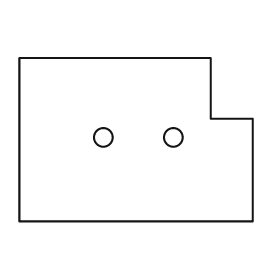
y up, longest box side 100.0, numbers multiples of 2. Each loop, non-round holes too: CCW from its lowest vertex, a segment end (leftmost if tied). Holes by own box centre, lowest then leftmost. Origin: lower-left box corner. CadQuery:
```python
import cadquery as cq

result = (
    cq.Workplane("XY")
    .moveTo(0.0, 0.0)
    .lineTo(100.0, 0.0)
    .lineTo(100.0, 44.0)
    .lineTo(82.0, 44.0)
    .lineTo(82.0, 70.0)
    .lineTo(0.0, 70.0)
    .close()
    .moveTo(36.0, 36.0)
    .circle(4.0)
    .moveTo(66.0, 36.0)
    .circle(4.0)
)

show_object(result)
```